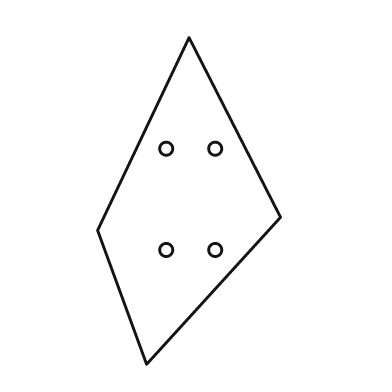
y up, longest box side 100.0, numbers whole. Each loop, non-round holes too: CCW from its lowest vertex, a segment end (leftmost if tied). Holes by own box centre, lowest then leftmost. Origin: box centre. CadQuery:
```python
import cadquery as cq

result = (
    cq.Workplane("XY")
    .moveTo(-13.0, -50.0)
    .lineTo(28.0, -5.0)
    .lineTo(0.0, 50.0)
    .lineTo(-28.0, -9.0)
    .close()
    .moveTo(-7.0, -15.0)
    .circle(2.0)
    .moveTo(8.0, -15.0)
    .circle(2.0)
    .moveTo(-7.0, 16.0)
    .circle(2.0)
    .moveTo(8.0, 16.0)
    .circle(2.0)
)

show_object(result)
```